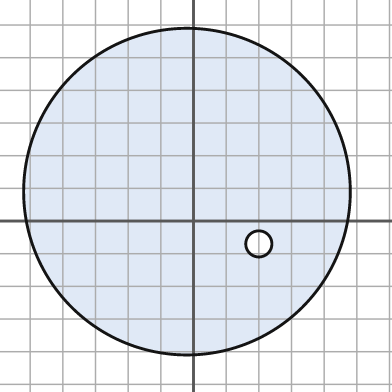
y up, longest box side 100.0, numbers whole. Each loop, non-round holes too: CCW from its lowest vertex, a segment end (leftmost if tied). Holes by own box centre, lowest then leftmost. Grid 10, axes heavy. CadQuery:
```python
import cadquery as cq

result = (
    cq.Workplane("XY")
    .moveTo(-2.0, 9.0)
    .circle(50.0)
    .moveTo(20.0, -7.0)
    .circle(4.0)
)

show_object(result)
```